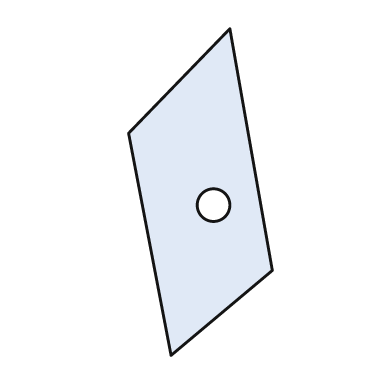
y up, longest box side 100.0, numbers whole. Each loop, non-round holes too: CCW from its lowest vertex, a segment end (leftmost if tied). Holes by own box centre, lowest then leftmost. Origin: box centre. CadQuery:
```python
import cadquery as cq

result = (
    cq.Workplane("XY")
    .moveTo(-9.0, -50.0)
    .lineTo(22.0, -24.0)
    .lineTo(9.0, 50.0)
    .lineTo(-22.0, 18.0)
    .close()
    .moveTo(4.0, -4.0)
    .circle(5.0)
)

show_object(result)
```